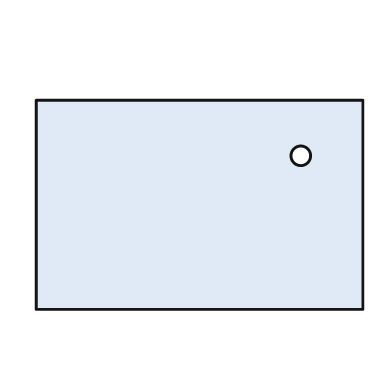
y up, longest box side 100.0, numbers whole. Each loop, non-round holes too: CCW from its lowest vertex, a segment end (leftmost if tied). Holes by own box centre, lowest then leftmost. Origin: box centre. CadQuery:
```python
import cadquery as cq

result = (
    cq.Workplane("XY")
    .moveTo(-50.0, -32.0)
    .lineTo(50.0, -32.0)
    .lineTo(50.0, 32.0)
    .lineTo(-50.0, 32.0)
    .close()
    .moveTo(31.0, 15.0)
    .circle(3.0)
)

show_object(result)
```